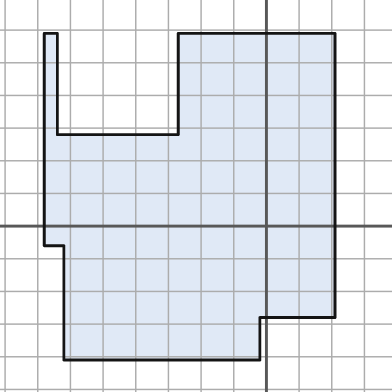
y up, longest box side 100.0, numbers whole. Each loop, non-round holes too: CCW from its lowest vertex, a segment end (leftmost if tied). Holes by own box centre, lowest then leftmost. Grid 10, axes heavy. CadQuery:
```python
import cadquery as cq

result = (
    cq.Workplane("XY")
    .moveTo(-62.0, -41.0)
    .lineTo(-2.0, -41.0)
    .lineTo(-2.0, -28.0)
    .lineTo(21.0, -28.0)
    .lineTo(21.0, 59.0)
    .lineTo(-27.0, 59.0)
    .lineTo(-27.0, 28.0)
    .lineTo(-64.0, 28.0)
    .lineTo(-64.0, 59.0)
    .lineTo(-68.0, 59.0)
    .lineTo(-68.0, -6.0)
    .lineTo(-62.0, -6.0)
    .close()
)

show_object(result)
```